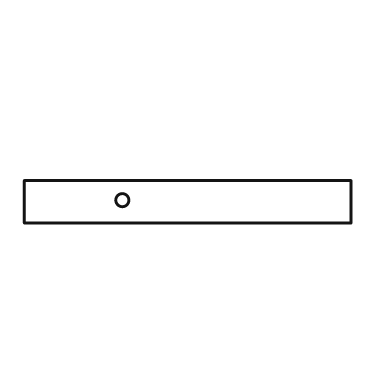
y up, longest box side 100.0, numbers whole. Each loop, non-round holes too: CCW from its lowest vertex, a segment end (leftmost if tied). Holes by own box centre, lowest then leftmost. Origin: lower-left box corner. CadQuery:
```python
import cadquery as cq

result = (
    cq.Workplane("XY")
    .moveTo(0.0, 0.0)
    .lineTo(100.0, 0.0)
    .lineTo(100.0, 13.0)
    .lineTo(0.0, 13.0)
    .close()
    .moveTo(30.0, 7.0)
    .circle(2.0)
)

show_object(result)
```